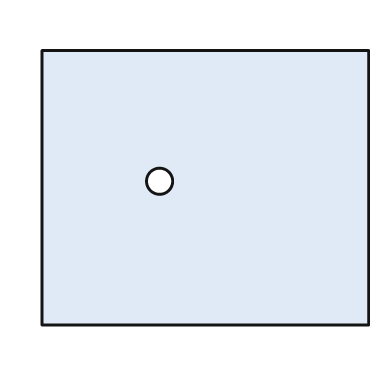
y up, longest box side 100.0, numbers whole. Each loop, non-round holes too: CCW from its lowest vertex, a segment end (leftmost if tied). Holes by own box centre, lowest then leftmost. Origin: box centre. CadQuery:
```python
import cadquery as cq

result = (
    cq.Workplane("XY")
    .moveTo(-50.0, -42.0)
    .lineTo(50.0, -42.0)
    .lineTo(50.0, 42.0)
    .lineTo(-50.0, 42.0)
    .close()
    .moveTo(-14.0, 2.0)
    .circle(4.0)
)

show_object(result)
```